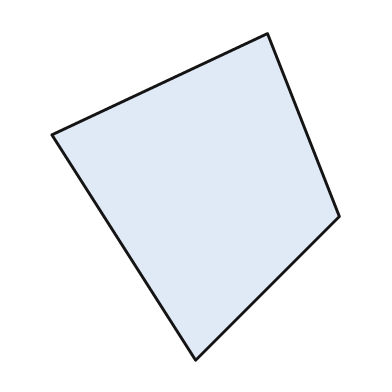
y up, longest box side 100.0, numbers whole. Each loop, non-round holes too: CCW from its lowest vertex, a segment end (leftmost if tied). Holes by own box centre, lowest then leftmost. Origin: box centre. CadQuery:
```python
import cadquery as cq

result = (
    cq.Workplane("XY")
    .moveTo(0.0, -50.0)
    .lineTo(44.0, -6.0)
    .lineTo(22.0, 50.0)
    .lineTo(-44.0, 19.0)
    .close()
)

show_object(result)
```